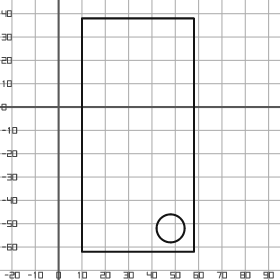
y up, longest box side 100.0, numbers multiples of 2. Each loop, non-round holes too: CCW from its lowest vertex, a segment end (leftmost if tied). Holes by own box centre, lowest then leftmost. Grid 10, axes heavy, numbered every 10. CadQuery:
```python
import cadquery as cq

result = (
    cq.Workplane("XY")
    .moveTo(10.0, -62.0)
    .lineTo(58.0, -62.0)
    .lineTo(58.0, 38.0)
    .lineTo(10.0, 38.0)
    .close()
    .moveTo(48.0, -52.0)
    .circle(6.0)
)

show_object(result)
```